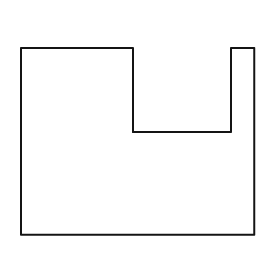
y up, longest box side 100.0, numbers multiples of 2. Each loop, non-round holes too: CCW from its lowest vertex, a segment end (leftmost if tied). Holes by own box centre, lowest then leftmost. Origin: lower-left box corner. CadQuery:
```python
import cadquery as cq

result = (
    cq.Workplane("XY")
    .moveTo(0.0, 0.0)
    .lineTo(100.0, 0.0)
    .lineTo(100.0, 80.0)
    .lineTo(90.0, 80.0)
    .lineTo(90.0, 44.0)
    .lineTo(48.0, 44.0)
    .lineTo(48.0, 80.0)
    .lineTo(0.0, 80.0)
    .close()
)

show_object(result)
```